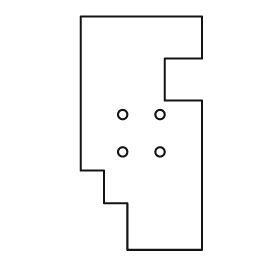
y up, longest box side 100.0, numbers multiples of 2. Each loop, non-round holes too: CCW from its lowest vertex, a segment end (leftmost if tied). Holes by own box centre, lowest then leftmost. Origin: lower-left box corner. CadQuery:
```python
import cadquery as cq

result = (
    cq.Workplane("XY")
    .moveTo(20.0, 0.0)
    .lineTo(52.0, 0.0)
    .lineTo(52.0, 64.0)
    .lineTo(36.0, 64.0)
    .lineTo(36.0, 82.0)
    .lineTo(52.0, 82.0)
    .lineTo(52.0, 100.0)
    .lineTo(0.0, 100.0)
    .lineTo(0.0, 34.0)
    .lineTo(10.0, 34.0)
    .lineTo(10.0, 20.0)
    .lineTo(20.0, 20.0)
    .close()
    .moveTo(18.0, 42.0)
    .circle(2.0)
    .moveTo(34.0, 42.0)
    .circle(2.0)
    .moveTo(18.0, 58.0)
    .circle(2.0)
    .moveTo(34.0, 58.0)
    .circle(2.0)
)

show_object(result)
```